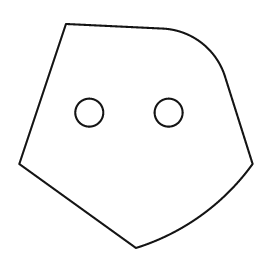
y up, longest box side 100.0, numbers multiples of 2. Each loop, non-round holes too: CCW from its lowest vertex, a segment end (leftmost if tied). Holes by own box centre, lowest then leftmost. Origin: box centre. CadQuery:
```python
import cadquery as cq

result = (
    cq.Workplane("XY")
    .moveTo(0.0, -48.0)
    .threePointArc((28.0, -34.0), (50.0, -12.0))
    .lineTo(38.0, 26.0)
    .threePointArc((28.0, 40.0), (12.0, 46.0))
    .lineTo(-30.0, 48.0)
    .lineTo(-50.0, -12.0)
    .close()
    .moveTo(-20.0, 10.0)
    .circle(6.0)
    .moveTo(14.0, 10.0)
    .circle(6.0)
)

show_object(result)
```